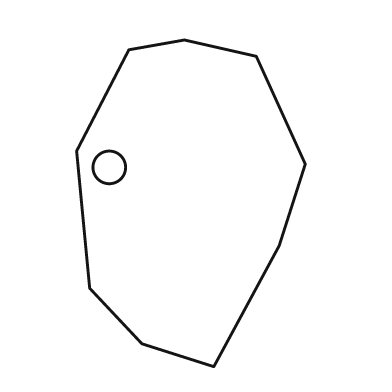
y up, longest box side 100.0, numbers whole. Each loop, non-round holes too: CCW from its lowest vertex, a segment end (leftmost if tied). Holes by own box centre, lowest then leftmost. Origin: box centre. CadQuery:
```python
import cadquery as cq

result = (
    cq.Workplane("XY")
    .moveTo(7.0, -50.0)
    .lineTo(27.0, -13.0)
    .lineTo(35.0, 12.0)
    .lineTo(20.0, 45.0)
    .lineTo(-2.0, 50.0)
    .lineTo(-19.0, 47.0)
    .lineTo(-35.0, 16.0)
    .lineTo(-31.0, -26.0)
    .lineTo(-15.0, -43.0)
    .close()
    .moveTo(-25.0, 11.0)
    .circle(5.0)
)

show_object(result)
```